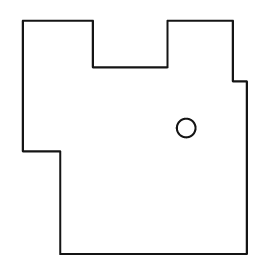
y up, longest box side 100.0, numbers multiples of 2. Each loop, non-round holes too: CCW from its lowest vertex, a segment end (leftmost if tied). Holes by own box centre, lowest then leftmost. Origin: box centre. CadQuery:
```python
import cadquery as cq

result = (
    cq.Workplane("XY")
    .moveTo(-32.0, -50.0)
    .lineTo(48.0, -50.0)
    .lineTo(48.0, 24.0)
    .lineTo(42.0, 24.0)
    .lineTo(42.0, 50.0)
    .lineTo(14.0, 50.0)
    .lineTo(14.0, 30.0)
    .lineTo(-18.0, 30.0)
    .lineTo(-18.0, 50.0)
    .lineTo(-48.0, 50.0)
    .lineTo(-48.0, -6.0)
    .lineTo(-32.0, -6.0)
    .close()
    .moveTo(22.0, 4.0)
    .circle(4.0)
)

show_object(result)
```